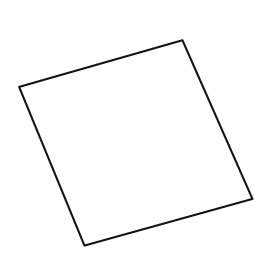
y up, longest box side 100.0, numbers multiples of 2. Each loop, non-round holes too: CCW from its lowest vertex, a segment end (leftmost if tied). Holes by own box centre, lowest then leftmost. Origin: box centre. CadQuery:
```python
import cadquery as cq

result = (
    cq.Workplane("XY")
    .moveTo(-22.0, -44.0)
    .lineTo(50.0, -24.0)
    .lineTo(20.0, 44.0)
    .lineTo(-50.0, 24.0)
    .close()
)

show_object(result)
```